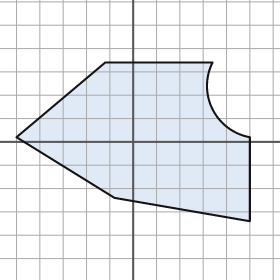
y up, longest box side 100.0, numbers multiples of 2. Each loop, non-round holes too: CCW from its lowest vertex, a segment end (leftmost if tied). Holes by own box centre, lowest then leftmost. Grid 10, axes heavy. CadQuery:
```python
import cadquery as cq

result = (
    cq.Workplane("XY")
    .moveTo(50.0, -34.0)
    .lineTo(50.0, 2.0)
    .threePointArc((34.0, 14.0), (34.0, 34.0))
    .lineTo(-12.0, 34.0)
    .lineTo(-50.0, 2.0)
    .lineTo(-8.0, -24.0)
    .close()
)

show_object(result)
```